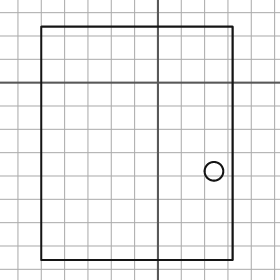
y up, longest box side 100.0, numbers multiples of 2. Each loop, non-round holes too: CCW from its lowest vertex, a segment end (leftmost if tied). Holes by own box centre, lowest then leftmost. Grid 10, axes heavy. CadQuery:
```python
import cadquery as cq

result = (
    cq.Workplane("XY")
    .moveTo(-50.0, -76.0)
    .lineTo(32.0, -76.0)
    .lineTo(32.0, 24.0)
    .lineTo(-50.0, 24.0)
    .close()
    .moveTo(24.0, -38.0)
    .circle(4.0)
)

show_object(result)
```